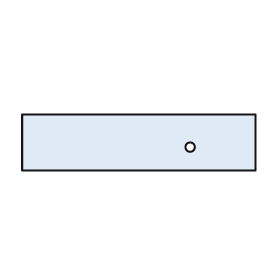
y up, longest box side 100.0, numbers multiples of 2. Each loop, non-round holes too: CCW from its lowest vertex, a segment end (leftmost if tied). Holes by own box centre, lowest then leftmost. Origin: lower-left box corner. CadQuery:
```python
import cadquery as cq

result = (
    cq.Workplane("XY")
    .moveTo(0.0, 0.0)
    .lineTo(100.0, 0.0)
    .lineTo(100.0, 24.0)
    .lineTo(0.0, 24.0)
    .close()
    .moveTo(72.0, 10.0)
    .circle(2.0)
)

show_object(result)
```